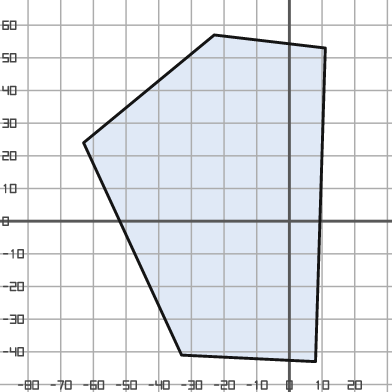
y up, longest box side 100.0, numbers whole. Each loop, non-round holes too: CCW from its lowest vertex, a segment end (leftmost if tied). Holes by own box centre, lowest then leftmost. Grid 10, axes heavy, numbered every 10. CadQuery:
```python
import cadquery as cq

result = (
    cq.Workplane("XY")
    .moveTo(8.0, -43.0)
    .lineTo(11.0, 53.0)
    .lineTo(-23.0, 57.0)
    .lineTo(-63.0, 24.0)
    .lineTo(-33.0, -41.0)
    .close()
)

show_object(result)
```